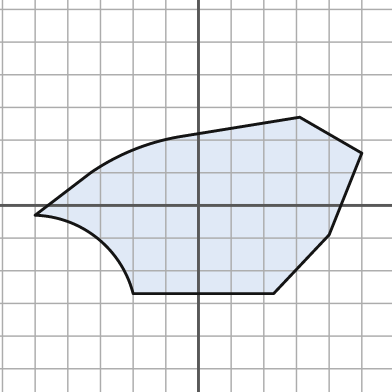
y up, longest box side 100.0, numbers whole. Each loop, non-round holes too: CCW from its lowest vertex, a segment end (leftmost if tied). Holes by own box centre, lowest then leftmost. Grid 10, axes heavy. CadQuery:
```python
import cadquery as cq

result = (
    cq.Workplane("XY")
    .moveTo(-20.0, -27.0)
    .lineTo(23.0, -27.0)
    .lineTo(40.0, -9.0)
    .lineTo(50.0, 16.0)
    .lineTo(31.0, 27.0)
    .lineTo(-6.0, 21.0)
    .threePointArc((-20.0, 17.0), (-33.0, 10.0))
    .lineTo(-50.0, -3.0)
    .threePointArc((-31.0, -10.0), (-20.0, -27.0))
    .close()
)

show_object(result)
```